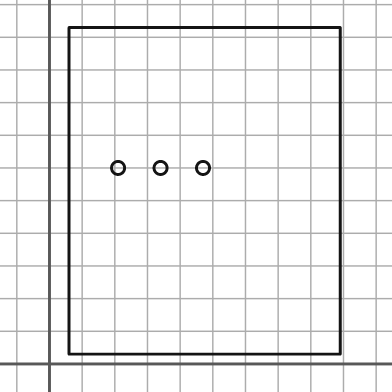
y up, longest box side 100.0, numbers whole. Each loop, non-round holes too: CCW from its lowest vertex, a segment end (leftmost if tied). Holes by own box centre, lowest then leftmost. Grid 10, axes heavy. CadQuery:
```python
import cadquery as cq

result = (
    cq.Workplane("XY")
    .moveTo(6.0, 3.0)
    .lineTo(89.0, 3.0)
    .lineTo(89.0, 103.0)
    .lineTo(6.0, 103.0)
    .close()
    .moveTo(21.0, 60.0)
    .circle(2.0)
    .moveTo(34.0, 60.0)
    .circle(2.0)
    .moveTo(47.0, 60.0)
    .circle(2.0)
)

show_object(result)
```